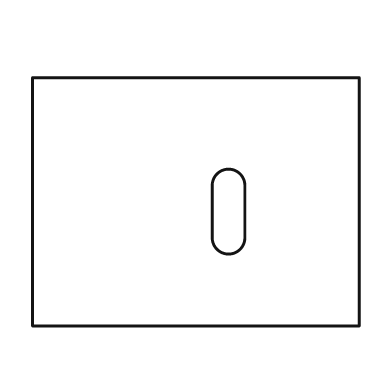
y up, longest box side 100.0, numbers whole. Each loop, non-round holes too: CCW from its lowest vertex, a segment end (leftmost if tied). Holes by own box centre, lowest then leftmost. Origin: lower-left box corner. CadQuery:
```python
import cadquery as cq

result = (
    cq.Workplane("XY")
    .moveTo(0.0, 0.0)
    .lineTo(100.0, 0.0)
    .lineTo(100.0, 76.0)
    .lineTo(0.0, 76.0)
    .close()
    .moveTo(55.0, 27.0)
    .threePointArc((60.0, 22.0), (65.0, 27.0))
    .lineTo(65.0, 43.0)
    .threePointArc((60.0, 48.0), (55.0, 43.0))
    .close()
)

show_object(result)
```